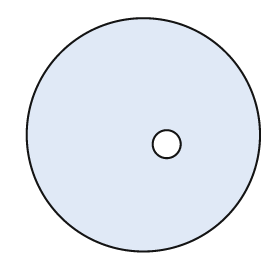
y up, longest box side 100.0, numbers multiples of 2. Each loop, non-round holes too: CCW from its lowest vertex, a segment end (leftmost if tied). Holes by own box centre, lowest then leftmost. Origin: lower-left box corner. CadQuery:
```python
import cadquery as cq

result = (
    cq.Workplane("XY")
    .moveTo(50.0, 50.0)
    .circle(50.0)
    .moveTo(60.0, 46.0)
    .circle(6.0)
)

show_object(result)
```